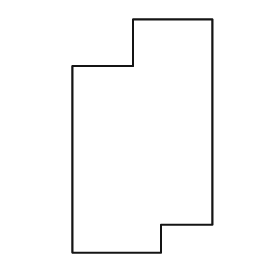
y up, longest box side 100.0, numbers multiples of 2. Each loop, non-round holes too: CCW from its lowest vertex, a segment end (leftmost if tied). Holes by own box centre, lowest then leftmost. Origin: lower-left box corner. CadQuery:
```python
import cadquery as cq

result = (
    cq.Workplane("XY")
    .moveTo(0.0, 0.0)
    .lineTo(38.0, 0.0)
    .lineTo(38.0, 12.0)
    .lineTo(60.0, 12.0)
    .lineTo(60.0, 100.0)
    .lineTo(26.0, 100.0)
    .lineTo(26.0, 80.0)
    .lineTo(0.0, 80.0)
    .close()
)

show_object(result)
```